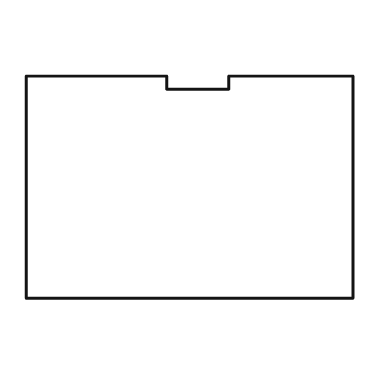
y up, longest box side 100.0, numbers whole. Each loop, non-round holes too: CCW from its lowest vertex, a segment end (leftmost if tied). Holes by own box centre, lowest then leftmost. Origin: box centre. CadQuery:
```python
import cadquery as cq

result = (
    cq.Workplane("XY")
    .moveTo(-50.0, -34.0)
    .lineTo(50.0, -34.0)
    .lineTo(50.0, 34.0)
    .lineTo(12.0, 34.0)
    .lineTo(12.0, 30.0)
    .lineTo(-7.0, 30.0)
    .lineTo(-7.0, 34.0)
    .lineTo(-50.0, 34.0)
    .close()
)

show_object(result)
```